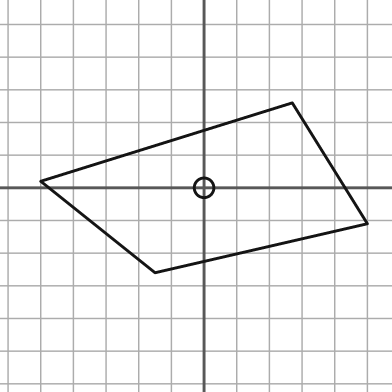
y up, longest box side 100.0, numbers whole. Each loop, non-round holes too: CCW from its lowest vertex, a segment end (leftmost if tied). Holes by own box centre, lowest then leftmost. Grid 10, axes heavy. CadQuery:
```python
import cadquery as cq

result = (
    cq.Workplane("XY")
    .moveTo(-15.0, -26.0)
    .lineTo(50.0, -11.0)
    .lineTo(27.0, 26.0)
    .lineTo(-50.0, 2.0)
    .close()
    .moveTo(0.0, 0.0)
    .circle(3.0)
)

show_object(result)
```